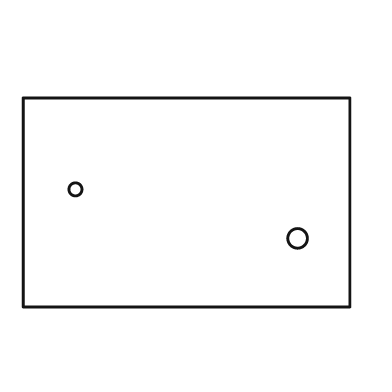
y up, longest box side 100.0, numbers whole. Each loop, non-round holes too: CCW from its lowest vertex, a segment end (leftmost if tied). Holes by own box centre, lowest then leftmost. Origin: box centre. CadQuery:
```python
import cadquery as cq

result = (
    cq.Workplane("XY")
    .moveTo(-50.0, -32.0)
    .lineTo(50.0, -32.0)
    .lineTo(50.0, 32.0)
    .lineTo(-50.0, 32.0)
    .close()
    .moveTo(34.0, -11.0)
    .circle(3.0)
    .moveTo(-34.0, 4.0)
    .circle(2.0)
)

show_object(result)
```